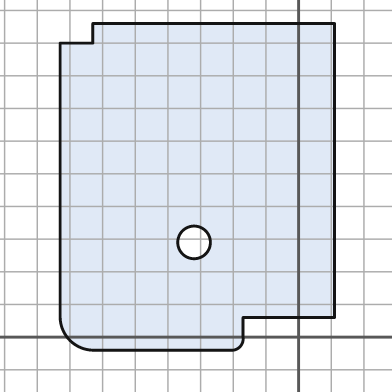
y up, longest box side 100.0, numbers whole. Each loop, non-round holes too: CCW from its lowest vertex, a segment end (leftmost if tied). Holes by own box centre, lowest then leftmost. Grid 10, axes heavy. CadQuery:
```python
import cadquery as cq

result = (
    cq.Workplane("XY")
    .moveTo(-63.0, -4.0)
    .lineTo(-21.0, -4.0)
    .threePointArc((-18.0, -3.0), (-17.0, 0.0))
    .lineTo(-17.0, 6.0)
    .lineTo(11.0, 6.0)
    .lineTo(11.0, 96.0)
    .lineTo(-63.0, 96.0)
    .lineTo(-63.0, 90.0)
    .lineTo(-73.0, 90.0)
    .lineTo(-73.0, 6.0)
    .threePointArc((-70.0, -1.0), (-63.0, -4.0))
    .close()
    .moveTo(-32.0, 29.0)
    .circle(5.0)
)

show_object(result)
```